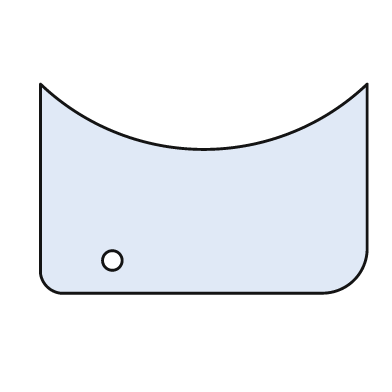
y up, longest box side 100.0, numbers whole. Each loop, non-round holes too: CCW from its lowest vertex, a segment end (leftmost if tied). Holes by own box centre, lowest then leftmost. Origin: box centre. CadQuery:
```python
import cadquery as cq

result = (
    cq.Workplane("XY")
    .moveTo(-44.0, -32.0)
    .lineTo(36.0, -32.0)
    .threePointArc((46.0, -28.0), (50.0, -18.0))
    .lineTo(50.0, 32.0)
    .threePointArc((0.0, 12.0), (-50.0, 32.0))
    .lineTo(-50.0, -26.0)
    .threePointArc((-48.0, -30.0), (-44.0, -32.0))
    .close()
    .moveTo(-28.0, -22.0)
    .circle(3.0)
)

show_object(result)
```